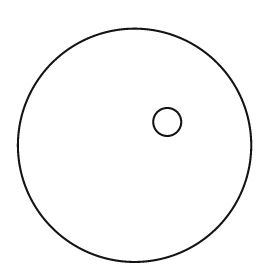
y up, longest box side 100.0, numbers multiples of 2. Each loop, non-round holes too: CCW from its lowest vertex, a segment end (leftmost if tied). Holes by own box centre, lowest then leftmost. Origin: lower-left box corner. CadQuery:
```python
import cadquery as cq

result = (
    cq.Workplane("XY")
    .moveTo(50.0, 50.0)
    .circle(50.0)
    .moveTo(64.0, 60.0)
    .circle(6.0)
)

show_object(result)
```